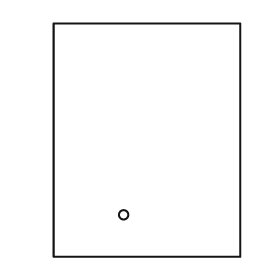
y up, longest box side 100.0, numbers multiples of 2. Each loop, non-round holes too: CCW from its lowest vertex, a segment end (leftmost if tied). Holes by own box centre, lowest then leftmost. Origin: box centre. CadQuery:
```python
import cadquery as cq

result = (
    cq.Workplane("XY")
    .moveTo(-40.0, -50.0)
    .lineTo(40.0, -50.0)
    .lineTo(40.0, 50.0)
    .lineTo(-40.0, 50.0)
    .close()
    .moveTo(-10.0, -32.0)
    .circle(2.0)
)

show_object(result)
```